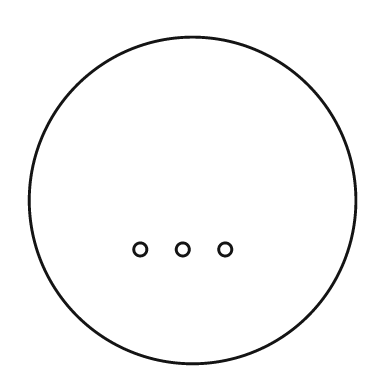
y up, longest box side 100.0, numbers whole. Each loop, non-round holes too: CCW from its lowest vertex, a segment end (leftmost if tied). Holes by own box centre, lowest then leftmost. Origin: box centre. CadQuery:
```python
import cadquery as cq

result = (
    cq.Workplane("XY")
    .moveTo(0.0, 0.0)
    .circle(50.0)
    .moveTo(-16.0, -15.0)
    .circle(2.0)
    .moveTo(-3.0, -15.0)
    .circle(2.0)
    .moveTo(10.0, -15.0)
    .circle(2.0)
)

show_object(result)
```